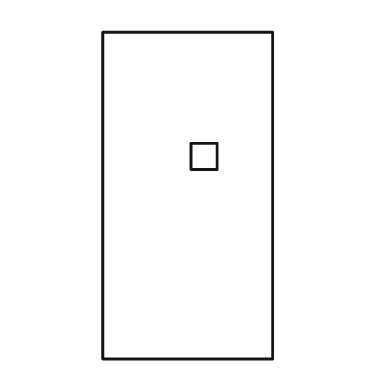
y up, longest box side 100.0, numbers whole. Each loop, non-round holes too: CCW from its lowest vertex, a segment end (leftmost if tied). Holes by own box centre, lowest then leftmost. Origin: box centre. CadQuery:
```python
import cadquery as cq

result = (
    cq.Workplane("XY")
    .moveTo(-26.0, -50.0)
    .lineTo(26.0, -50.0)
    .lineTo(26.0, 50.0)
    .lineTo(-26.0, 50.0)
    .close()
    .moveTo(1.0, 8.0)
    .lineTo(9.0, 8.0)
    .lineTo(9.0, 16.0)
    .lineTo(1.0, 16.0)
    .close()
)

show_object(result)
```